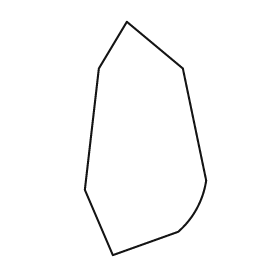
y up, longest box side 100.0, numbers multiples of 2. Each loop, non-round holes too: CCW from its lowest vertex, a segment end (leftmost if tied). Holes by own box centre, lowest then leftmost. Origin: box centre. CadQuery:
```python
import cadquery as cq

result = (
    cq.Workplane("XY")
    .moveTo(-14.0, -50.0)
    .lineTo(14.0, -40.0)
    .threePointArc((22.0, -30.0), (26.0, -18.0))
    .lineTo(16.0, 30.0)
    .lineTo(-8.0, 50.0)
    .lineTo(-20.0, 30.0)
    .lineTo(-26.0, -22.0)
    .close()
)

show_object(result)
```